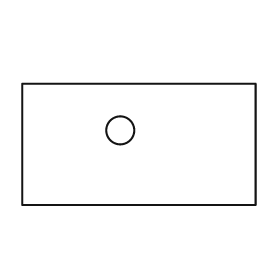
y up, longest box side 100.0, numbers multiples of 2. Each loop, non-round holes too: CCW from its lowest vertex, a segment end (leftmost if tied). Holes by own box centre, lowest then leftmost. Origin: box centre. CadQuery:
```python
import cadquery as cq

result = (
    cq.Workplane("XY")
    .moveTo(-50.0, -26.0)
    .lineTo(50.0, -26.0)
    .lineTo(50.0, 26.0)
    .lineTo(-50.0, 26.0)
    .close()
    .moveTo(-8.0, 6.0)
    .circle(6.0)
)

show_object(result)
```